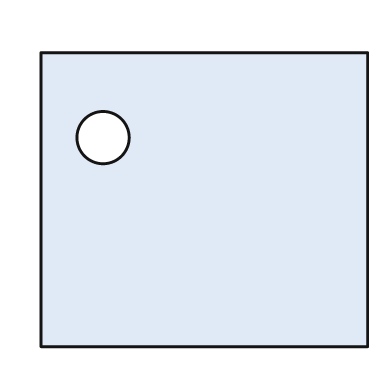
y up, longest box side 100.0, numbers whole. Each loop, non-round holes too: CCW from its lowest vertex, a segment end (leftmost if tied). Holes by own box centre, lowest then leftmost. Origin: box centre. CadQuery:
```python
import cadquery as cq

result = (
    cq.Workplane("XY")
    .moveTo(-50.0, -45.0)
    .lineTo(50.0, -45.0)
    .lineTo(50.0, 45.0)
    .lineTo(-50.0, 45.0)
    .close()
    .moveTo(-31.0, 19.0)
    .circle(8.0)
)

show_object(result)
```